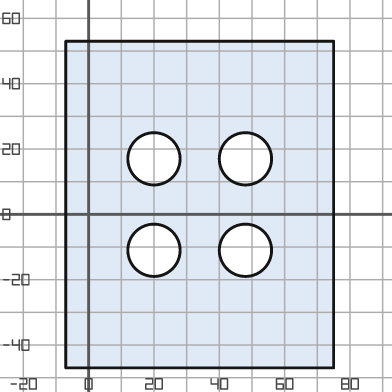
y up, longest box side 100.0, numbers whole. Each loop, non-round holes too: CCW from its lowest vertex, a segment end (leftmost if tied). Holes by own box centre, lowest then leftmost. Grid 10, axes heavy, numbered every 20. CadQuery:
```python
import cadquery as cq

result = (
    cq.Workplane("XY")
    .moveTo(-7.0, -47.0)
    .lineTo(75.0, -47.0)
    .lineTo(75.0, 53.0)
    .lineTo(-7.0, 53.0)
    .close()
    .moveTo(20.0, -11.0)
    .circle(8.0)
    .moveTo(48.0, -11.0)
    .circle(8.0)
    .moveTo(20.0, 17.0)
    .circle(8.0)
    .moveTo(48.0, 17.0)
    .circle(8.0)
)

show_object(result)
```